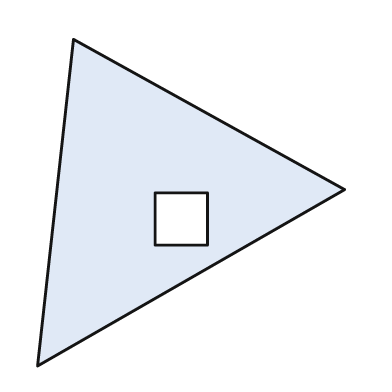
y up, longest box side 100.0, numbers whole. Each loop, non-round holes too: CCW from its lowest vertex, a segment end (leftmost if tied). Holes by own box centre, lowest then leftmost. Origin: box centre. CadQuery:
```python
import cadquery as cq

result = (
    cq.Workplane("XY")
    .moveTo(-47.0, -50.0)
    .lineTo(47.0, 4.0)
    .lineTo(-36.0, 50.0)
    .close()
    .moveTo(-11.0, -13.0)
    .lineTo(5.0, -13.0)
    .lineTo(5.0, 3.0)
    .lineTo(-11.0, 3.0)
    .close()
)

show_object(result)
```